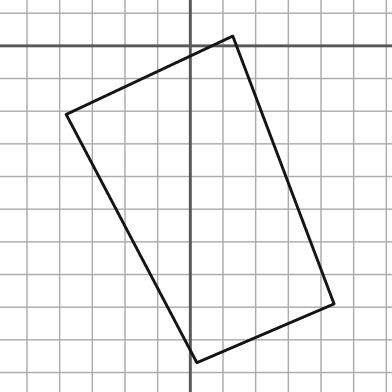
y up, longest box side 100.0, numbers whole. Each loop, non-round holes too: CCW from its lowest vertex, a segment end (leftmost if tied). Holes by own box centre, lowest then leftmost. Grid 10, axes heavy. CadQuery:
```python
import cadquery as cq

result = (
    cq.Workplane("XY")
    .moveTo(2.0, -97.0)
    .lineTo(44.0, -79.0)
    .lineTo(13.0, 3.0)
    .lineTo(-38.0, -21.0)
    .close()
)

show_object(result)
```